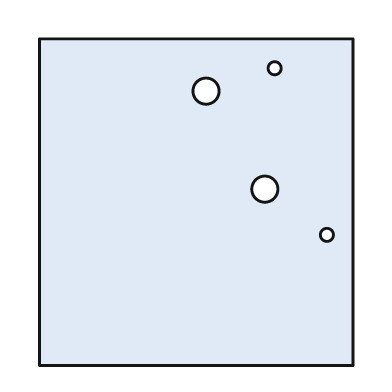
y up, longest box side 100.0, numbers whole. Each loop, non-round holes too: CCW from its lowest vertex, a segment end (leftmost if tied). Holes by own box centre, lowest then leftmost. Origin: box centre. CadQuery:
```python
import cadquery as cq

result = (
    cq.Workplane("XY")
    .moveTo(-48.0, -50.0)
    .lineTo(48.0, -50.0)
    .lineTo(48.0, 50.0)
    .lineTo(-48.0, 50.0)
    .close()
    .moveTo(40.0, -10.0)
    .circle(2.0)
    .moveTo(21.0, 4.0)
    .circle(4.0)
    .moveTo(3.0, 34.0)
    .circle(4.0)
    .moveTo(24.0, 41.0)
    .circle(2.0)
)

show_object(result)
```